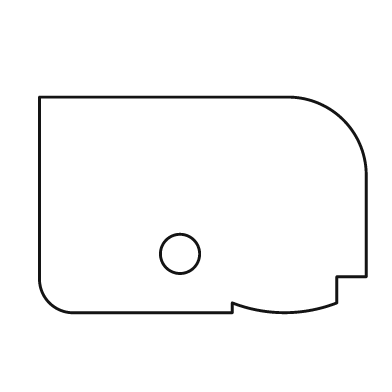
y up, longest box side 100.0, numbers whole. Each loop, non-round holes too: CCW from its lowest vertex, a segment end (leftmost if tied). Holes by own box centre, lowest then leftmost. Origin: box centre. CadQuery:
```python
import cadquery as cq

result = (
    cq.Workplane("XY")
    .moveTo(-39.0, -33.0)
    .lineTo(9.0, -33.0)
    .lineTo(9.0, -30.0)
    .threePointArc((25.0, -33.0), (41.0, -30.0))
    .lineTo(41.0, -22.0)
    .lineTo(50.0, -22.0)
    .lineTo(50.0, 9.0)
    .threePointArc((43.0, 26.0), (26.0, 33.0))
    .lineTo(-50.0, 33.0)
    .lineTo(-50.0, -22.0)
    .threePointArc((-47.0, -30.0), (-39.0, -33.0))
    .close()
    .moveTo(-7.0, -15.0)
    .circle(6.0)
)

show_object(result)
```